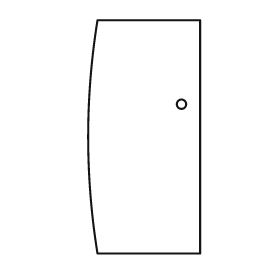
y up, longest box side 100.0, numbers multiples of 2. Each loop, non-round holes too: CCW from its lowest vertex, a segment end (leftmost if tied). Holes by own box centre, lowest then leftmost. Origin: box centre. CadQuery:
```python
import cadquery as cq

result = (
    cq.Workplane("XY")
    .moveTo(-20.0, -50.0)
    .lineTo(24.0, -50.0)
    .lineTo(24.0, 50.0)
    .lineTo(-20.0, 50.0)
    .threePointArc((-24.0, 0.0), (-20.0, -50.0))
    .close()
    .moveTo(16.0, 14.0)
    .circle(2.0)
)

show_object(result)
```